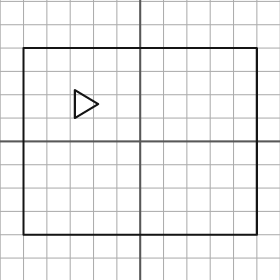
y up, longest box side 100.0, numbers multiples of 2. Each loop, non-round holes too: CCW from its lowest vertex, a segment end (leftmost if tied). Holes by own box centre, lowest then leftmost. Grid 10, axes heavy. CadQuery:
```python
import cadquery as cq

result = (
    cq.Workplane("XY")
    .moveTo(-50.0, -40.0)
    .lineTo(50.0, -40.0)
    .lineTo(50.0, 40.0)
    .lineTo(-50.0, 40.0)
    .close()
    .moveTo(-28.0, 10.0)
    .lineTo(-18.0, 16.0)
    .lineTo(-28.0, 22.0)
    .close()
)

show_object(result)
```